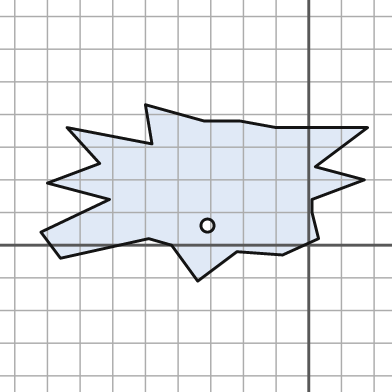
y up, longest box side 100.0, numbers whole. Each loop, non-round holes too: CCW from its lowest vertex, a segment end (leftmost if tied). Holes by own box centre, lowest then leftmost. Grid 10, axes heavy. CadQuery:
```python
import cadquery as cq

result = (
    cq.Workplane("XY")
    .moveTo(-34.0, -11.0)
    .lineTo(-22.0, -2.0)
    .lineTo(-8.0, -3.0)
    .lineTo(3.0, 2.0)
    .lineTo(1.0, 10.0)
    .lineTo(1.0, 14.0)
    .lineTo(17.0, 20.0)
    .lineTo(2.0, 24.0)
    .lineTo(18.0, 36.0)
    .lineTo(-10.0, 36.0)
    .lineTo(-21.0, 38.0)
    .lineTo(-32.0, 38.0)
    .lineTo(-50.0, 43.0)
    .lineTo(-48.0, 31.0)
    .lineTo(-74.0, 36.0)
    .lineTo(-64.0, 25.0)
    .lineTo(-80.0, 19.0)
    .lineTo(-61.0, 14.0)
    .lineTo(-82.0, 4.0)
    .lineTo(-76.0, -4.0)
    .lineTo(-49.0, 2.0)
    .lineTo(-42.0, 0.0)
    .close()
    .moveTo(-31.0, 6.0)
    .circle(2.0)
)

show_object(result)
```